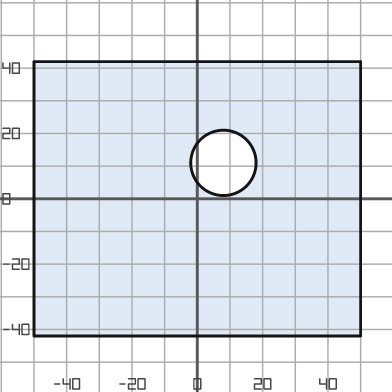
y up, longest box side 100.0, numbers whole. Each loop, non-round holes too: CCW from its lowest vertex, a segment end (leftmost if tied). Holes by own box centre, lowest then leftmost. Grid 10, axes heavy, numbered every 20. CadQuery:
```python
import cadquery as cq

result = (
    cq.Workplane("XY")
    .moveTo(-50.0, -42.0)
    .lineTo(50.0, -42.0)
    .lineTo(50.0, 42.0)
    .lineTo(-50.0, 42.0)
    .close()
    .moveTo(8.0, 11.0)
    .circle(10.0)
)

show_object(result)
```